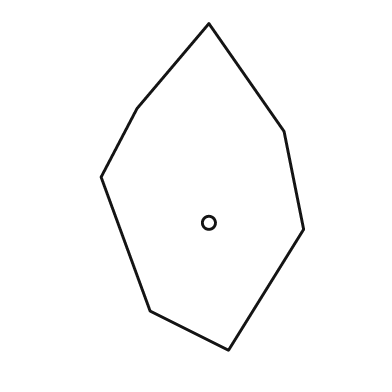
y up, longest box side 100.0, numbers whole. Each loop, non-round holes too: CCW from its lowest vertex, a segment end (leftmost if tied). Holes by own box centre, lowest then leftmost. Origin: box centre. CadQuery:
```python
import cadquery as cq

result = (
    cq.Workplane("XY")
    .moveTo(8.0, -50.0)
    .lineTo(31.0, -13.0)
    .lineTo(25.0, 17.0)
    .lineTo(2.0, 50.0)
    .lineTo(-20.0, 24.0)
    .lineTo(-31.0, 3.0)
    .lineTo(-16.0, -38.0)
    .close()
    .moveTo(2.0, -11.0)
    .circle(2.0)
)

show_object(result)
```